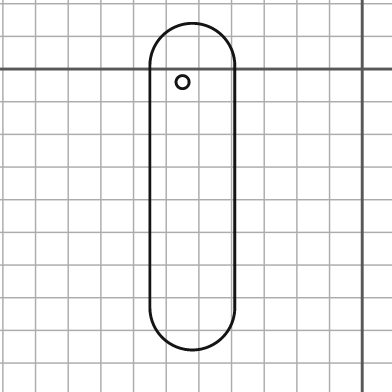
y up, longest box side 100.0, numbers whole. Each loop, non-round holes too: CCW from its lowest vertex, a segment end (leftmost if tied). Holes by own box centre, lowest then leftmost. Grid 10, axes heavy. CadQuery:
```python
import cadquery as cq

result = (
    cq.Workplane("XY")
    .moveTo(-65.0, -73.0)
    .threePointArc((-52.0, -86.0), (-39.0, -73.0))
    .lineTo(-39.0, 1.0)
    .threePointArc((-52.0, 14.0), (-65.0, 1.0))
    .close()
    .moveTo(-55.0, -4.0)
    .circle(2.0)
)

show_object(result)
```